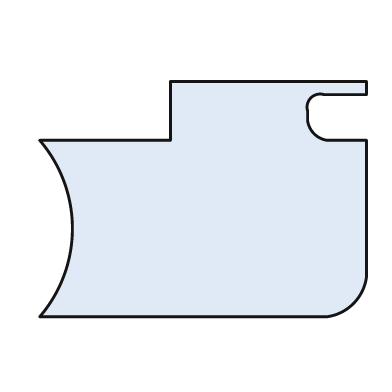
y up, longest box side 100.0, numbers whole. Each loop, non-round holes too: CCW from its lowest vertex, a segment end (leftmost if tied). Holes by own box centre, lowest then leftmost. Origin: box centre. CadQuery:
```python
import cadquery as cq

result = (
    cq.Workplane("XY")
    .moveTo(-50.0, -36.0)
    .lineTo(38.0, -36.0)
    .threePointArc((46.0, -32.0), (50.0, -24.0))
    .lineTo(50.0, 18.0)
    .lineTo(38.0, 18.0)
    .threePointArc((34.0, 20.0), (32.0, 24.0))
    .lineTo(32.0, 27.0)
    .threePointArc((33.0, 31.0), (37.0, 32.0))
    .lineTo(50.0, 32.0)
    .lineTo(50.0, 36.0)
    .lineTo(-10.0, 36.0)
    .lineTo(-10.0, 18.0)
    .lineTo(-50.0, 18.0)
    .threePointArc((-40.0, -9.0), (-50.0, -36.0))
    .close()
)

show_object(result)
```